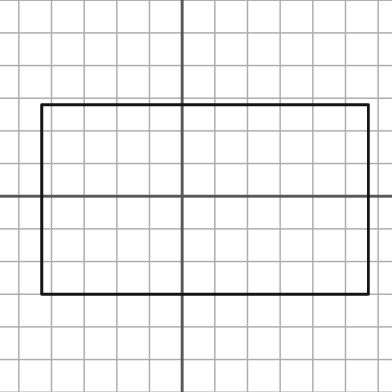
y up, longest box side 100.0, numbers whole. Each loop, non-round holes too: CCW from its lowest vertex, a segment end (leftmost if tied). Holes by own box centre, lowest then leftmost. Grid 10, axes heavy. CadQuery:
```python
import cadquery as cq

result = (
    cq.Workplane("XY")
    .moveTo(-43.0, -30.0)
    .lineTo(57.0, -30.0)
    .lineTo(57.0, 28.0)
    .lineTo(-43.0, 28.0)
    .close()
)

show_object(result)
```